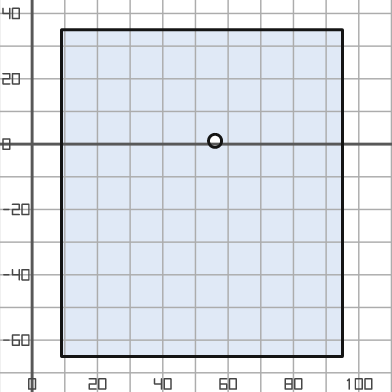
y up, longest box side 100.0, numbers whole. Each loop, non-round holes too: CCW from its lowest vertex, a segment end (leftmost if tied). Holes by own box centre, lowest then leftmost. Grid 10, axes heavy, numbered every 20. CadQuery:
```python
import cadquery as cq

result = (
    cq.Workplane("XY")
    .moveTo(9.0, -65.0)
    .lineTo(95.0, -65.0)
    .lineTo(95.0, 35.0)
    .lineTo(9.0, 35.0)
    .close()
    .moveTo(56.0, 1.0)
    .circle(2.0)
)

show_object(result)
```